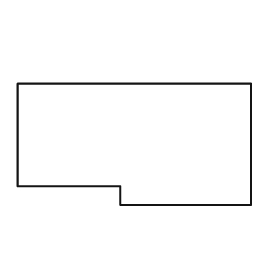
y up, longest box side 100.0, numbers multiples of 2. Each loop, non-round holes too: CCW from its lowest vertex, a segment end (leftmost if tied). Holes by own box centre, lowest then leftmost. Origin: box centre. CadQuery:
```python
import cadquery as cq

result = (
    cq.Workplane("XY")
    .moveTo(-6.0, -26.0)
    .lineTo(50.0, -26.0)
    .lineTo(50.0, 26.0)
    .lineTo(-50.0, 26.0)
    .lineTo(-50.0, -18.0)
    .lineTo(-6.0, -18.0)
    .close()
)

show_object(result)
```